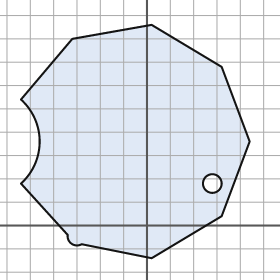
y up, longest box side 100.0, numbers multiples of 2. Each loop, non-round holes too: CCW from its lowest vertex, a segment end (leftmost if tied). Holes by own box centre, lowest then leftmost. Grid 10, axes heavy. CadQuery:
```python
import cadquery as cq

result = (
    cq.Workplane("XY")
    .moveTo(2.0, -14.0)
    .lineTo(32.0, 4.0)
    .lineTo(44.0, 36.0)
    .lineTo(32.0, 68.0)
    .lineTo(2.0, 86.0)
    .lineTo(-32.0, 80.0)
    .lineTo(-54.0, 54.0)
    .threePointArc((-46.0, 36.0), (-54.0, 18.0))
    .lineTo(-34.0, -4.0)
    .threePointArc((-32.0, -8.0), (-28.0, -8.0))
    .close()
    .moveTo(28.0, 18.0)
    .circle(4.0)
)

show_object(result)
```